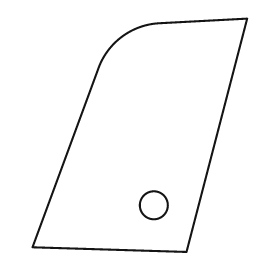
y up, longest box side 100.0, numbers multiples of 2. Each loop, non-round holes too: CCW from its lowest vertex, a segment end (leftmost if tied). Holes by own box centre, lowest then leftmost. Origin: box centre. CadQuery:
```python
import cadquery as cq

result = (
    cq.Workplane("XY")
    .moveTo(20.0, -50.0)
    .lineTo(46.0, 50.0)
    .lineTo(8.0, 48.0)
    .threePointArc((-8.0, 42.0), (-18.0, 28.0))
    .lineTo(-46.0, -48.0)
    .close()
    .moveTo(6.0, -30.0)
    .circle(6.0)
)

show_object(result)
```